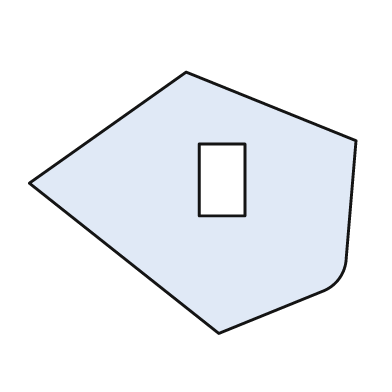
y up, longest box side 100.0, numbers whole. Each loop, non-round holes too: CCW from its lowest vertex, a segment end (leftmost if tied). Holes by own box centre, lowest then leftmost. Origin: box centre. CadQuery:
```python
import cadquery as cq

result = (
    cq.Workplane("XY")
    .moveTo(8.0, -40.0)
    .lineTo(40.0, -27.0)
    .threePointArc((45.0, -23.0), (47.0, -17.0))
    .lineTo(50.0, 19.0)
    .lineTo(-2.0, 40.0)
    .lineTo(-50.0, 6.0)
    .close()
    .moveTo(2.0, -4.0)
    .lineTo(16.0, -4.0)
    .lineTo(16.0, 18.0)
    .lineTo(2.0, 18.0)
    .close()
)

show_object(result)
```